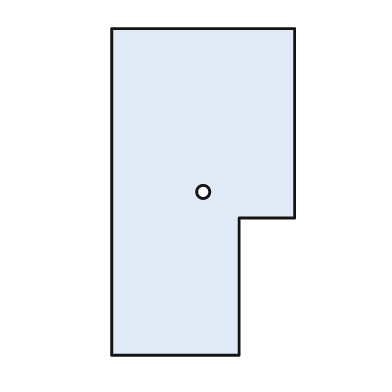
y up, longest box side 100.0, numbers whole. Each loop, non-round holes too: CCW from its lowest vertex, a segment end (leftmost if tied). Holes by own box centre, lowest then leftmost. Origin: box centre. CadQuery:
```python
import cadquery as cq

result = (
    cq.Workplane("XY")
    .moveTo(-28.0, -50.0)
    .lineTo(11.0, -50.0)
    .lineTo(11.0, -8.0)
    .lineTo(28.0, -8.0)
    .lineTo(28.0, 50.0)
    .lineTo(-28.0, 50.0)
    .close()
    .moveTo(0.0, 0.0)
    .circle(2.0)
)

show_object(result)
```